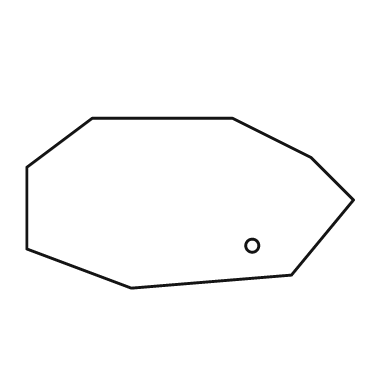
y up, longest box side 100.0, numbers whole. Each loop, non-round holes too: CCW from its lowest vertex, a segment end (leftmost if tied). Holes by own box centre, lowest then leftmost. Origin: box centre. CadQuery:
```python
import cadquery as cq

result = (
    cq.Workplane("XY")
    .moveTo(-18.0, -26.0)
    .lineTo(31.0, -22.0)
    .lineTo(50.0, 1.0)
    .lineTo(37.0, 14.0)
    .lineTo(13.0, 26.0)
    .lineTo(-30.0, 26.0)
    .lineTo(-50.0, 11.0)
    .lineTo(-50.0, -14.0)
    .close()
    .moveTo(19.0, -13.0)
    .circle(2.0)
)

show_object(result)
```